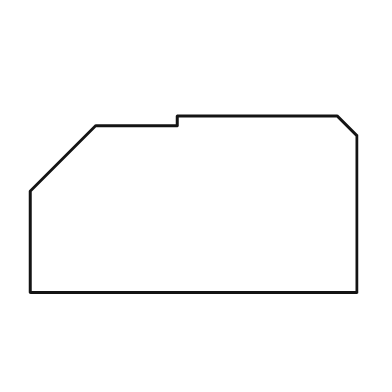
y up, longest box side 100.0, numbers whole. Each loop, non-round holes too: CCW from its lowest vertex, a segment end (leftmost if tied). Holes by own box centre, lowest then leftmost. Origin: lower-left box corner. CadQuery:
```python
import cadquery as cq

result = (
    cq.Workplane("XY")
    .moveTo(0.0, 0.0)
    .lineTo(100.0, 0.0)
    .lineTo(100.0, 48.0)
    .lineTo(94.0, 54.0)
    .lineTo(45.0, 54.0)
    .lineTo(45.0, 51.0)
    .lineTo(20.0, 51.0)
    .lineTo(0.0, 31.0)
    .close()
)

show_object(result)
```